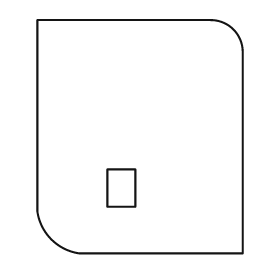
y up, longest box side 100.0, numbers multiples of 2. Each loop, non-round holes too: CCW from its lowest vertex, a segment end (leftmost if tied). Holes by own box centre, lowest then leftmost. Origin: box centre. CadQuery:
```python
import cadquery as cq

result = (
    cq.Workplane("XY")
    .moveTo(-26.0, -50.0)
    .lineTo(44.0, -50.0)
    .lineTo(44.0, 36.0)
    .threePointArc((40.0, 46.0), (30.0, 50.0))
    .lineTo(-44.0, 50.0)
    .lineTo(-44.0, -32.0)
    .threePointArc((-38.0, -44.0), (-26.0, -50.0))
    .close()
    .moveTo(-14.0, -30.0)
    .lineTo(-2.0, -30.0)
    .lineTo(-2.0, -14.0)
    .lineTo(-14.0, -14.0)
    .close()
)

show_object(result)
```